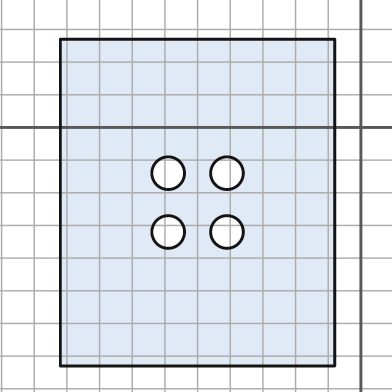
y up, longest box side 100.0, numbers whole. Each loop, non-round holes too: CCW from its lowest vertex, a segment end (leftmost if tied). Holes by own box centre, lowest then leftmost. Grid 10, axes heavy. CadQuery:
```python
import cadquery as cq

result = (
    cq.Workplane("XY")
    .moveTo(-92.0, -73.0)
    .lineTo(-8.0, -73.0)
    .lineTo(-8.0, 27.0)
    .lineTo(-92.0, 27.0)
    .close()
    .moveTo(-59.0, -32.0)
    .circle(5.0)
    .moveTo(-41.0, -32.0)
    .circle(5.0)
    .moveTo(-59.0, -14.0)
    .circle(5.0)
    .moveTo(-41.0, -14.0)
    .circle(5.0)
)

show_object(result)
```